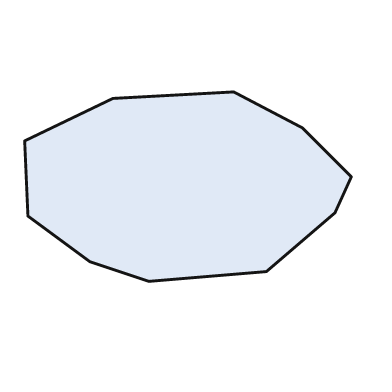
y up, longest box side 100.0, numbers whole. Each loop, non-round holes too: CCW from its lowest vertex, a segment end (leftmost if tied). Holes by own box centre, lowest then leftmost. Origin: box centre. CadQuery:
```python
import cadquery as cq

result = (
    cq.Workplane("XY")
    .moveTo(-12.0, -29.0)
    .lineTo(24.0, -26.0)
    .lineTo(45.0, -8.0)
    .lineTo(50.0, 3.0)
    .lineTo(35.0, 18.0)
    .lineTo(14.0, 29.0)
    .lineTo(-23.0, 27.0)
    .lineTo(-50.0, 14.0)
    .lineTo(-49.0, -9.0)
    .lineTo(-30.0, -23.0)
    .close()
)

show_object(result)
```